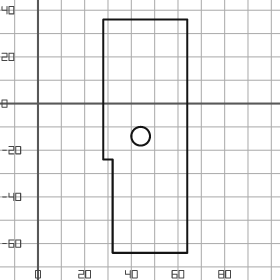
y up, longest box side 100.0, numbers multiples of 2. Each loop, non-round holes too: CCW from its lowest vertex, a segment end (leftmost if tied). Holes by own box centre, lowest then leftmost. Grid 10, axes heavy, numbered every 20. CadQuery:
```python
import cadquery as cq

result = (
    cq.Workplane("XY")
    .moveTo(32.0, -64.0)
    .lineTo(64.0, -64.0)
    .lineTo(64.0, 36.0)
    .lineTo(28.0, 36.0)
    .lineTo(28.0, -24.0)
    .lineTo(32.0, -24.0)
    .close()
    .moveTo(44.0, -14.0)
    .circle(4.0)
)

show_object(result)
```